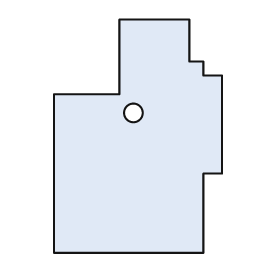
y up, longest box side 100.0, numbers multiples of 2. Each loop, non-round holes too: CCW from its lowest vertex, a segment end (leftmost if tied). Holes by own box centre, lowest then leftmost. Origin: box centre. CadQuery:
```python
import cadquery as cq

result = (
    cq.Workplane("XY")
    .moveTo(-36.0, -50.0)
    .lineTo(28.0, -50.0)
    .lineTo(28.0, -16.0)
    .lineTo(36.0, -16.0)
    .lineTo(36.0, 26.0)
    .lineTo(28.0, 26.0)
    .lineTo(28.0, 32.0)
    .lineTo(22.0, 32.0)
    .lineTo(22.0, 50.0)
    .lineTo(-8.0, 50.0)
    .lineTo(-8.0, 18.0)
    .lineTo(-36.0, 18.0)
    .close()
    .moveTo(-2.0, 10.0)
    .circle(4.0)
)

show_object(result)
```